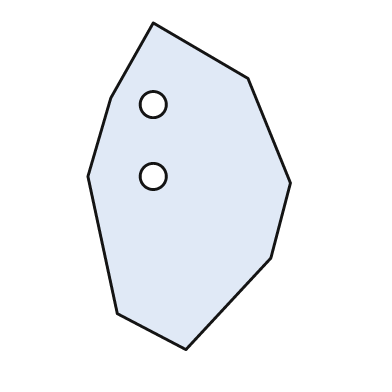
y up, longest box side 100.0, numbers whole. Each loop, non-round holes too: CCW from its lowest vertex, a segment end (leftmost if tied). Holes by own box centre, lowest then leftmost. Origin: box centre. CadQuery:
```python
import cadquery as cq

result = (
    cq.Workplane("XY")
    .moveTo(-1.0, -50.0)
    .lineTo(25.0, -22.0)
    .lineTo(31.0, 1.0)
    .lineTo(18.0, 33.0)
    .lineTo(-11.0, 50.0)
    .lineTo(-24.0, 27.0)
    .lineTo(-31.0, 3.0)
    .lineTo(-22.0, -39.0)
    .close()
    .moveTo(-11.0, 3.0)
    .circle(4.0)
    .moveTo(-11.0, 25.0)
    .circle(4.0)
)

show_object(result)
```